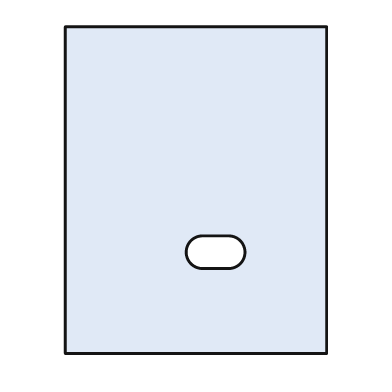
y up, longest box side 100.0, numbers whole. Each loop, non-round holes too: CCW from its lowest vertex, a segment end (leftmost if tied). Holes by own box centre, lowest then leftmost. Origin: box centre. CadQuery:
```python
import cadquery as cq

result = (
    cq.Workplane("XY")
    .moveTo(-40.0, -50.0)
    .lineTo(40.0, -50.0)
    .lineTo(40.0, 50.0)
    .lineTo(-40.0, 50.0)
    .close()
    .moveTo(2.0, -24.0)
    .lineTo(10.0, -24.0)
    .threePointArc((15.0, -19.0), (10.0, -14.0))
    .lineTo(2.0, -14.0)
    .threePointArc((-3.0, -19.0), (2.0, -24.0))
    .close()
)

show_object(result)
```